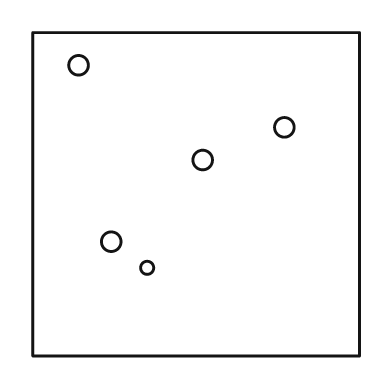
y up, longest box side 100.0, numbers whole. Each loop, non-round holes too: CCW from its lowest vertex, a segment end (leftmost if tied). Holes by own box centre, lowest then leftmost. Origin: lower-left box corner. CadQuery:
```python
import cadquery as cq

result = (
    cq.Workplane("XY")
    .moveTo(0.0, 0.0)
    .lineTo(100.0, 0.0)
    .lineTo(100.0, 99.0)
    .lineTo(0.0, 99.0)
    .close()
    .moveTo(35.0, 27.0)
    .circle(2.0)
    .moveTo(24.0, 35.0)
    .circle(3.0)
    .moveTo(52.0, 60.0)
    .circle(3.0)
    .moveTo(77.0, 70.0)
    .circle(3.0)
    .moveTo(14.0, 89.0)
    .circle(3.0)
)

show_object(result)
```